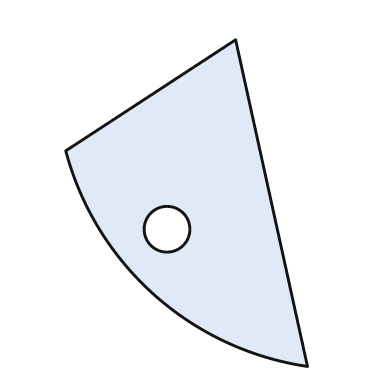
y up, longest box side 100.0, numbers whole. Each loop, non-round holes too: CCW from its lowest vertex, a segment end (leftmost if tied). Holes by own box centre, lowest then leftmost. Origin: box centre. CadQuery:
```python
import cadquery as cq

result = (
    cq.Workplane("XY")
    .moveTo(37.0, -50.0)
    .lineTo(15.0, 50.0)
    .lineTo(-37.0, 16.0)
    .threePointArc((-10.0, -28.0), (37.0, -50.0))
    .close()
    .moveTo(-6.0, -8.0)
    .circle(7.0)
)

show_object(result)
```